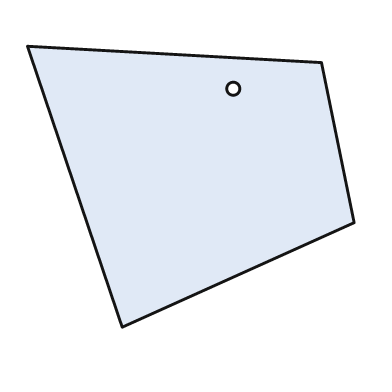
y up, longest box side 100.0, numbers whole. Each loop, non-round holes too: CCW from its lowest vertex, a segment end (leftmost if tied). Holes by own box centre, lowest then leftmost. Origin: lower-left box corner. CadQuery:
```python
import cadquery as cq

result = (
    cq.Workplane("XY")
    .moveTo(29.0, 0.0)
    .lineTo(100.0, 32.0)
    .lineTo(90.0, 81.0)
    .lineTo(0.0, 86.0)
    .close()
    .moveTo(63.0, 73.0)
    .circle(2.0)
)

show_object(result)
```